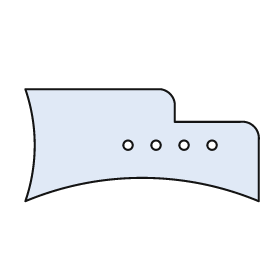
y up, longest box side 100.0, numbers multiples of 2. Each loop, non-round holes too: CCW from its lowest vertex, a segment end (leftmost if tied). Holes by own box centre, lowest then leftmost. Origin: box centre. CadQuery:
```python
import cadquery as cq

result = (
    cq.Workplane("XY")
    .moveTo(-50.0, -24.0)
    .threePointArc((0.0, -14.0), (50.0, -24.0))
    .lineTo(50.0, 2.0)
    .threePointArc((48.0, 8.0), (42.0, 10.0))
    .lineTo(14.0, 10.0)
    .lineTo(14.0, 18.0)
    .threePointArc((12.0, 22.0), (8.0, 24.0))
    .lineTo(-50.0, 24.0)
    .threePointArc((-46.0, 0.0), (-50.0, -24.0))
    .close()
    .moveTo(-6.0, 0.0)
    .circle(2.0)
    .moveTo(6.0, 0.0)
    .circle(2.0)
    .moveTo(18.0, 0.0)
    .circle(2.0)
    .moveTo(30.0, 0.0)
    .circle(2.0)
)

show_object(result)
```